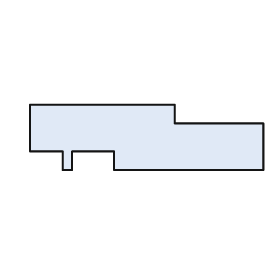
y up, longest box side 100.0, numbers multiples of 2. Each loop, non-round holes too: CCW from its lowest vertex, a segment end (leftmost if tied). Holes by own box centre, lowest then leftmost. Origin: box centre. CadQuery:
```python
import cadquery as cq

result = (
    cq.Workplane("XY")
    .moveTo(-36.0, -14.0)
    .lineTo(-32.0, -14.0)
    .lineTo(-32.0, -6.0)
    .lineTo(-14.0, -6.0)
    .lineTo(-14.0, -14.0)
    .lineTo(50.0, -14.0)
    .lineTo(50.0, 6.0)
    .lineTo(12.0, 6.0)
    .lineTo(12.0, 14.0)
    .lineTo(-50.0, 14.0)
    .lineTo(-50.0, -6.0)
    .lineTo(-36.0, -6.0)
    .close()
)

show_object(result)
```